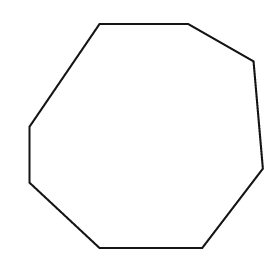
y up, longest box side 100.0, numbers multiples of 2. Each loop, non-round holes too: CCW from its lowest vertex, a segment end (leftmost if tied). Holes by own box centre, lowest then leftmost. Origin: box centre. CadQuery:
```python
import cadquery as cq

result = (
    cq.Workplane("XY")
    .moveTo(-20.0, -48.0)
    .lineTo(24.0, -48.0)
    .lineTo(50.0, -14.0)
    .lineTo(46.0, 32.0)
    .lineTo(18.0, 48.0)
    .lineTo(-20.0, 48.0)
    .lineTo(-50.0, 4.0)
    .lineTo(-50.0, -20.0)
    .close()
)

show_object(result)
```